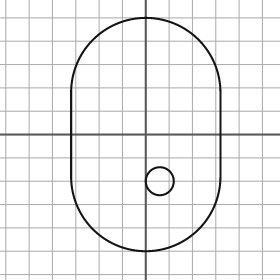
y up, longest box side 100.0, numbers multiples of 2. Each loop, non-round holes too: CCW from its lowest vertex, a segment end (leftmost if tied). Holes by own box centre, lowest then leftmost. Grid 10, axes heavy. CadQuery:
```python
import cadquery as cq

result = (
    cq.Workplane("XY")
    .moveTo(-32.0, -18.0)
    .threePointArc((0.0, -50.0), (32.0, -18.0))
    .lineTo(32.0, 18.0)
    .threePointArc((0.0, 50.0), (-32.0, 18.0))
    .close()
    .moveTo(6.0, -20.0)
    .circle(6.0)
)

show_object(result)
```